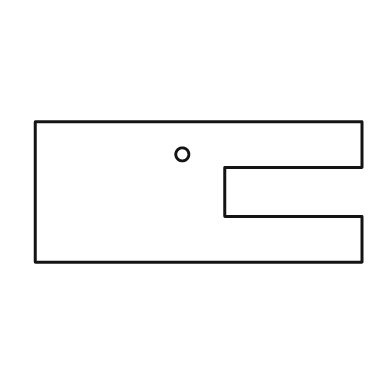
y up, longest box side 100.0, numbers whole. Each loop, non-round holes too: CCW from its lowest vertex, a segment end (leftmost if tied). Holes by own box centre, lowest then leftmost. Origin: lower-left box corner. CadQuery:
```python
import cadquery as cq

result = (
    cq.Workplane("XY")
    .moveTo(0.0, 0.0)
    .lineTo(100.0, 0.0)
    .lineTo(100.0, 14.0)
    .lineTo(58.0, 14.0)
    .lineTo(58.0, 29.0)
    .lineTo(100.0, 29.0)
    .lineTo(100.0, 43.0)
    .lineTo(0.0, 43.0)
    .close()
    .moveTo(45.0, 33.0)
    .circle(2.0)
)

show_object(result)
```